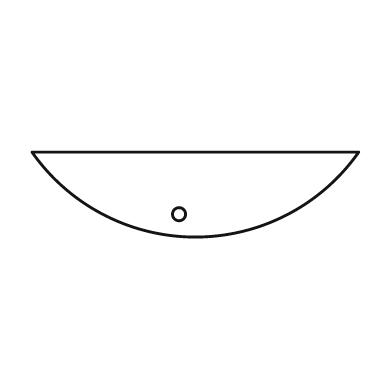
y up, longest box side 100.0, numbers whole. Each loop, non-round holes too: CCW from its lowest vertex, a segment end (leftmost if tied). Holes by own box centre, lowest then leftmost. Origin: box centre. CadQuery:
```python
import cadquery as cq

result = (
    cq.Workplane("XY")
    .moveTo(-50.0, 13.0)
    .threePointArc((0.0, -13.0), (50.0, 13.0))
    .close()
    .moveTo(-5.0, -6.0)
    .circle(2.0)
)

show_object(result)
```